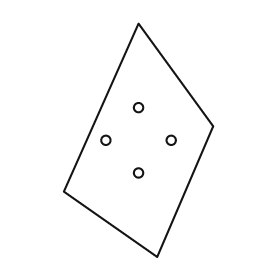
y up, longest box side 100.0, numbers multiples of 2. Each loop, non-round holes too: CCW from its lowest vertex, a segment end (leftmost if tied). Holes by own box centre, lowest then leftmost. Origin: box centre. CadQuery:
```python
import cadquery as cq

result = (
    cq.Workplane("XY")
    .moveTo(8.0, -50.0)
    .lineTo(32.0, 6.0)
    .lineTo(0.0, 50.0)
    .lineTo(-32.0, -22.0)
    .close()
    .moveTo(0.0, -14.0)
    .circle(2.0)
    .moveTo(-14.0, 0.0)
    .circle(2.0)
    .moveTo(14.0, 0.0)
    .circle(2.0)
    .moveTo(0.0, 14.0)
    .circle(2.0)
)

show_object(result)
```